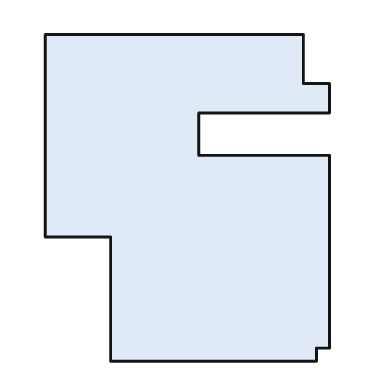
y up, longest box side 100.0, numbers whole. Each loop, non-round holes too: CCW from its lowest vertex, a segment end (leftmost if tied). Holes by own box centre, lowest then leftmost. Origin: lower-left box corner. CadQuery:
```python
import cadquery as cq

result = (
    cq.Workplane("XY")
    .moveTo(20.0, 0.0)
    .lineTo(83.0, 0.0)
    .lineTo(83.0, 4.0)
    .lineTo(87.0, 4.0)
    .lineTo(87.0, 63.0)
    .lineTo(47.0, 63.0)
    .lineTo(47.0, 76.0)
    .lineTo(87.0, 76.0)
    .lineTo(87.0, 85.0)
    .lineTo(79.0, 85.0)
    .lineTo(79.0, 100.0)
    .lineTo(0.0, 100.0)
    .lineTo(0.0, 38.0)
    .lineTo(20.0, 38.0)
    .close()
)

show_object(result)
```